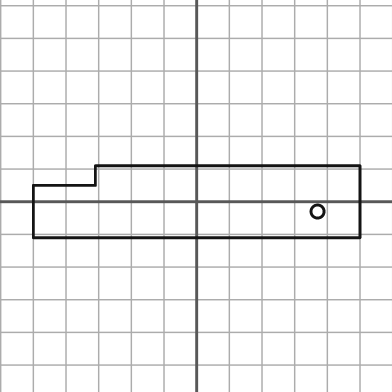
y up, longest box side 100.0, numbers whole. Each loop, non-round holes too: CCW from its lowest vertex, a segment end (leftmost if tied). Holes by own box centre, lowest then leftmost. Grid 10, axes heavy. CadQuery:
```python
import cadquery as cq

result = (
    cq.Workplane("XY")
    .moveTo(-50.0, -11.0)
    .lineTo(50.0, -11.0)
    .lineTo(50.0, 11.0)
    .lineTo(-31.0, 11.0)
    .lineTo(-31.0, 5.0)
    .lineTo(-50.0, 5.0)
    .close()
    .moveTo(37.0, -3.0)
    .circle(2.0)
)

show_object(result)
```